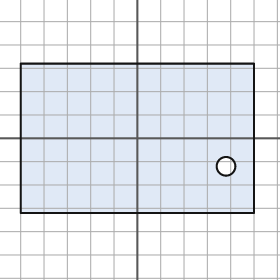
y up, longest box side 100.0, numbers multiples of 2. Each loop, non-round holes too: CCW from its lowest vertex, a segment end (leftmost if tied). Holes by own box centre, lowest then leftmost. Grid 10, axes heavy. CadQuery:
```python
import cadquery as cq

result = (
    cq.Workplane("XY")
    .moveTo(-50.0, -32.0)
    .lineTo(50.0, -32.0)
    .lineTo(50.0, 32.0)
    .lineTo(-50.0, 32.0)
    .close()
    .moveTo(38.0, -12.0)
    .circle(4.0)
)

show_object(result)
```